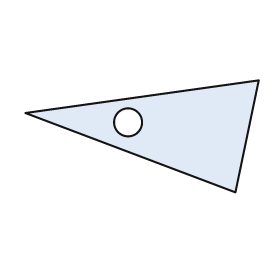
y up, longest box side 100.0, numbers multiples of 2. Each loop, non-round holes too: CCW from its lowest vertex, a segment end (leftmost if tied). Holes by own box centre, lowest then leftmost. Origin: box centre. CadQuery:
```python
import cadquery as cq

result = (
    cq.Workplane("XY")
    .moveTo(40.0, -24.0)
    .lineTo(50.0, 24.0)
    .lineTo(-50.0, 10.0)
    .close()
    .moveTo(-6.0, 6.0)
    .circle(6.0)
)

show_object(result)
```